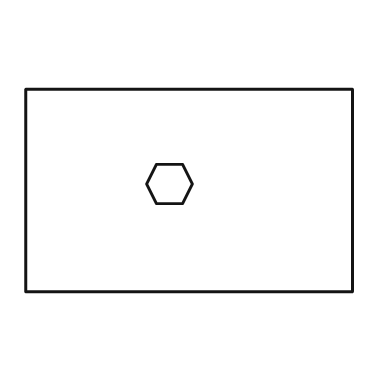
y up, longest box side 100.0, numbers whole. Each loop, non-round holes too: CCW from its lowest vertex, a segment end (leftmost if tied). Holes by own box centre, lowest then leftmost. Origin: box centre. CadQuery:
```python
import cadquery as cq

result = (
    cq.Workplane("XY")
    .moveTo(-50.0, -31.0)
    .lineTo(50.0, -31.0)
    .lineTo(50.0, 31.0)
    .lineTo(-50.0, 31.0)
    .close()
    .moveTo(-10.0, -4.0)
    .lineTo(-2.0, -4.0)
    .lineTo(1.0, 2.0)
    .lineTo(-2.0, 8.0)
    .lineTo(-10.0, 8.0)
    .lineTo(-13.0, 2.0)
    .close()
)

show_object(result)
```